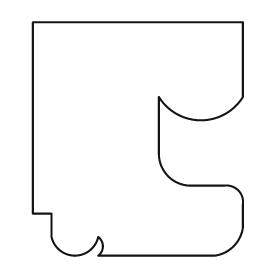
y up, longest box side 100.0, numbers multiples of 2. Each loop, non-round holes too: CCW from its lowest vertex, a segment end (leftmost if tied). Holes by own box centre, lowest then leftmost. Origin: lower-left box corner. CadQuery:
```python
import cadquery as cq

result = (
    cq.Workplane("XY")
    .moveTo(28.0, 0.0)
    .lineTo(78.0, 0.0)
    .threePointArc((86.0, 4.0), (90.0, 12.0))
    .lineTo(90.0, 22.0)
    .threePointArc((88.0, 28.0), (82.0, 30.0))
    .lineTo(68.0, 30.0)
    .threePointArc((58.0, 34.0), (54.0, 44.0))
    .lineTo(54.0, 68.0)
    .threePointArc((72.0, 58.0), (90.0, 68.0))
    .lineTo(90.0, 100.0)
    .lineTo(0.0, 100.0)
    .lineTo(0.0, 18.0)
    .lineTo(8.0, 18.0)
    .lineTo(8.0, 8.0)
    .threePointArc((18.0, 0.0), (28.0, 8.0))
    .threePointArc((30.0, 4.0), (28.0, 0.0))
    .close()
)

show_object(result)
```